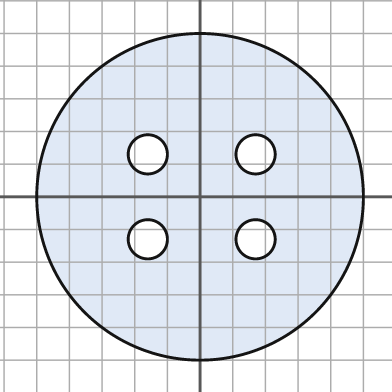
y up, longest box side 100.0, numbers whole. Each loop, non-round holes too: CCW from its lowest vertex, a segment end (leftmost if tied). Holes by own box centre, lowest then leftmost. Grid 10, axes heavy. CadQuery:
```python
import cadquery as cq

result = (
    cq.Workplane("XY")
    .moveTo(0.0, 0.0)
    .circle(50.0)
    .moveTo(-16.0, -13.0)
    .circle(6.0)
    .moveTo(17.0, -13.0)
    .circle(6.0)
    .moveTo(-16.0, 13.0)
    .circle(6.0)
    .moveTo(17.0, 13.0)
    .circle(6.0)
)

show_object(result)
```